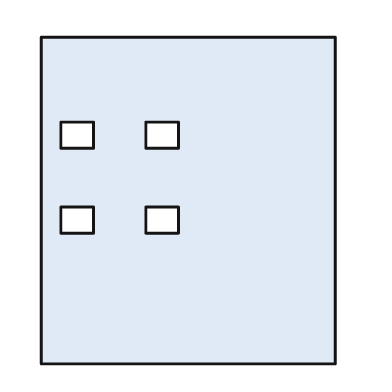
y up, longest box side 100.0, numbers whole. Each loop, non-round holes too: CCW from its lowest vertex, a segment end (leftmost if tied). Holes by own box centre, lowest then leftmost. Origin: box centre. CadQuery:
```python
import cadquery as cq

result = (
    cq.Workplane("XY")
    .moveTo(-45.0, -50.0)
    .lineTo(45.0, -50.0)
    .lineTo(45.0, 50.0)
    .lineTo(-45.0, 50.0)
    .close()
    .moveTo(-39.0, -10.0)
    .lineTo(-29.0, -10.0)
    .lineTo(-29.0, -2.0)
    .lineTo(-39.0, -2.0)
    .close()
    .moveTo(-13.0, -10.0)
    .lineTo(-3.0, -10.0)
    .lineTo(-3.0, -2.0)
    .lineTo(-13.0, -2.0)
    .close()
    .moveTo(-39.0, 16.0)
    .lineTo(-29.0, 16.0)
    .lineTo(-29.0, 24.0)
    .lineTo(-39.0, 24.0)
    .close()
    .moveTo(-13.0, 16.0)
    .lineTo(-3.0, 16.0)
    .lineTo(-3.0, 24.0)
    .lineTo(-13.0, 24.0)
    .close()
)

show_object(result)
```